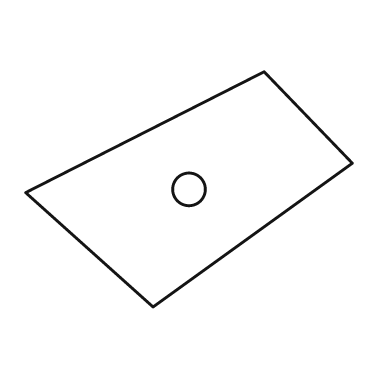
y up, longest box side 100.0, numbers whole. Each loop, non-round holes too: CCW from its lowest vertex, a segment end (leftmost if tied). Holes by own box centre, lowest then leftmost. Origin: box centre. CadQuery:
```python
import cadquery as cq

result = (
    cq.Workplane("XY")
    .moveTo(-11.0, -36.0)
    .lineTo(50.0, 8.0)
    .lineTo(23.0, 36.0)
    .lineTo(-50.0, -1.0)
    .close()
    .moveTo(0.0, 0.0)
    .circle(5.0)
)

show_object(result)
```